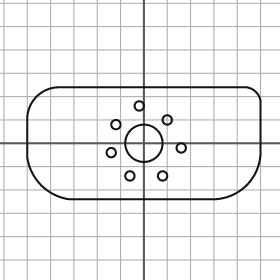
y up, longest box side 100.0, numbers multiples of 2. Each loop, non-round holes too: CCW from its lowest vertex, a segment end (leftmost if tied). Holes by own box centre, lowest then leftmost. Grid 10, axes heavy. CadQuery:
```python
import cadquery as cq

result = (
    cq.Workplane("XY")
    .moveTo(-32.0, -24.0)
    .lineTo(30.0, -24.0)
    .threePointArc((44.0, -18.0), (50.0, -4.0))
    .lineTo(50.0, 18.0)
    .threePointArc((48.0, 22.0), (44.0, 24.0))
    .lineTo(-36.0, 24.0)
    .threePointArc((-46.0, 20.0), (-50.0, 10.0))
    .lineTo(-50.0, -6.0)
    .threePointArc((-44.0, -18.0), (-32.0, -24.0))
    .close()
    .moveTo(-6.0, -14.0)
    .circle(2.0)
    .moveTo(8.0, -14.0)
    .circle(2.0)
    .moveTo(-14.0, -4.0)
    .circle(2.0)
    .moveTo(16.0, -2.0)
    .circle(2.0)
    .moveTo(0.0, 0.0)
    .circle(8.0)
    .moveTo(-12.0, 8.0)
    .circle(2.0)
    .moveTo(10.0, 10.0)
    .circle(2.0)
    .moveTo(-2.0, 16.0)
    .circle(2.0)
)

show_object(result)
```